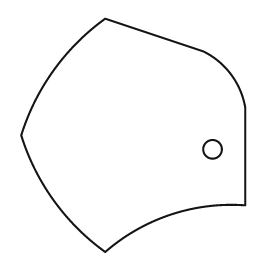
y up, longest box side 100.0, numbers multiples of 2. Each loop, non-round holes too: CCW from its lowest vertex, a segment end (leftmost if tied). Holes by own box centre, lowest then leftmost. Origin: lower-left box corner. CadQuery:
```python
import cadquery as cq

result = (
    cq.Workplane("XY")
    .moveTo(36.0, 0.0)
    .threePointArc((64.0, 16.0), (96.0, 20.0))
    .lineTo(96.0, 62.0)
    .threePointArc((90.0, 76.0), (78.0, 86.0))
    .lineTo(36.0, 100.0)
    .threePointArc((14.0, 78.0), (0.0, 50.0))
    .threePointArc((14.0, 22.0), (36.0, 0.0))
    .close()
    .moveTo(82.0, 44.0)
    .circle(4.0)
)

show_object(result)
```